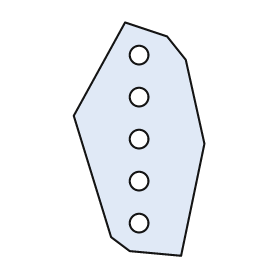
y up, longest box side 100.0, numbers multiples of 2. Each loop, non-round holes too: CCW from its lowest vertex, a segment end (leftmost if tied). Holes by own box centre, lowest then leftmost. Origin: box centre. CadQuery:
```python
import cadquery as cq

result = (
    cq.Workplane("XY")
    .moveTo(18.0, -50.0)
    .lineTo(28.0, -2.0)
    .lineTo(20.0, 34.0)
    .lineTo(12.0, 44.0)
    .lineTo(-6.0, 50.0)
    .lineTo(-28.0, 10.0)
    .lineTo(-12.0, -42.0)
    .lineTo(-4.0, -48.0)
    .close()
    .moveTo(0.0, -36.0)
    .circle(4.0)
    .moveTo(0.0, -18.0)
    .circle(4.0)
    .moveTo(0.0, 0.0)
    .circle(4.0)
    .moveTo(0.0, 18.0)
    .circle(4.0)
    .moveTo(0.0, 36.0)
    .circle(4.0)
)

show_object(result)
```